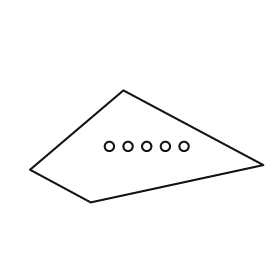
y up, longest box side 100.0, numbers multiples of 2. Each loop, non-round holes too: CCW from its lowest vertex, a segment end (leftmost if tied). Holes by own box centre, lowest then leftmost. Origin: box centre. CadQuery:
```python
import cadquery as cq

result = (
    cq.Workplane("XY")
    .moveTo(-24.0, -24.0)
    .lineTo(50.0, -8.0)
    .lineTo(-10.0, 24.0)
    .lineTo(-50.0, -10.0)
    .close()
    .moveTo(-16.0, 0.0)
    .circle(2.0)
    .moveTo(-8.0, 0.0)
    .circle(2.0)
    .moveTo(0.0, 0.0)
    .circle(2.0)
    .moveTo(8.0, 0.0)
    .circle(2.0)
    .moveTo(16.0, 0.0)
    .circle(2.0)
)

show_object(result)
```